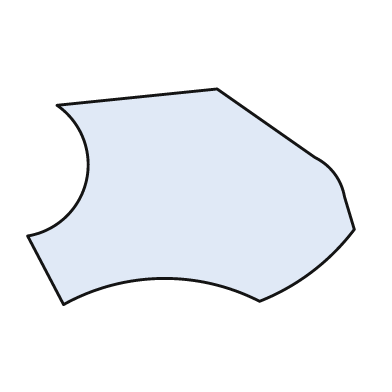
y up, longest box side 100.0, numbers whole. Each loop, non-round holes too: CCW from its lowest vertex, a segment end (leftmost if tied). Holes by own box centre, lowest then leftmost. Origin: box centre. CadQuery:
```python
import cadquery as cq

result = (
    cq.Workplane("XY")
    .moveTo(-39.0, -33.0)
    .threePointArc((-9.0, -25.0), (21.0, -32.0))
    .threePointArc((37.0, -23.0), (50.0, -10.0))
    .lineTo(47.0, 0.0)
    .threePointArc((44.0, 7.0), (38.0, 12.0))
    .lineTo(8.0, 33.0)
    .lineTo(-41.0, 28.0)
    .threePointArc((-32.0, 5.0), (-50.0, -12.0))
    .close()
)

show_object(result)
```